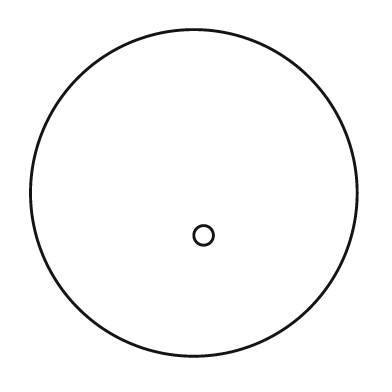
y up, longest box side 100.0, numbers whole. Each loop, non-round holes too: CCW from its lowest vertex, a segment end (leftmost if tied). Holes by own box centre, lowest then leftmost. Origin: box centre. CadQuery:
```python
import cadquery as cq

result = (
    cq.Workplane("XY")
    .moveTo(0.0, 0.0)
    .circle(50.0)
    .moveTo(3.0, -13.0)
    .circle(3.0)
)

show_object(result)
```